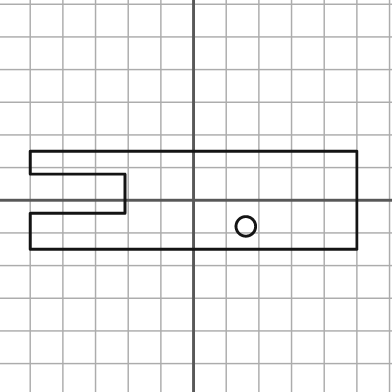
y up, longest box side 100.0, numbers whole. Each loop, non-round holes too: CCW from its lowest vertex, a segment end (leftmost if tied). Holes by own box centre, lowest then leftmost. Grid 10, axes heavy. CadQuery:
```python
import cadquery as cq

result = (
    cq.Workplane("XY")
    .moveTo(-50.0, -15.0)
    .lineTo(50.0, -15.0)
    .lineTo(50.0, 15.0)
    .lineTo(-50.0, 15.0)
    .lineTo(-50.0, 8.0)
    .lineTo(-21.0, 8.0)
    .lineTo(-21.0, -4.0)
    .lineTo(-50.0, -4.0)
    .close()
    .moveTo(16.0, -8.0)
    .circle(3.0)
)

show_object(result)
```